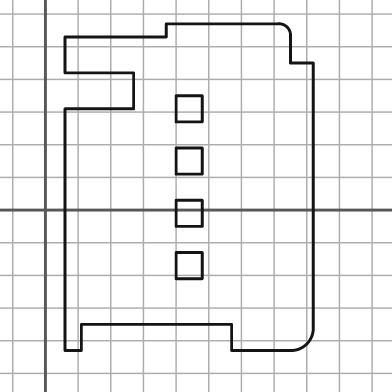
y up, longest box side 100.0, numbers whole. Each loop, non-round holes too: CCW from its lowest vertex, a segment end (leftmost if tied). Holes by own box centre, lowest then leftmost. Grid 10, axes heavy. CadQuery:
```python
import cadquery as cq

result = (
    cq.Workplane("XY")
    .moveTo(6.0, -43.0)
    .lineTo(11.0, -43.0)
    .lineTo(11.0, -35.0)
    .lineTo(57.0, -35.0)
    .lineTo(57.0, -43.0)
    .lineTo(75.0, -43.0)
    .threePointArc((80.0, -41.0), (82.0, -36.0))
    .lineTo(82.0, 45.0)
    .lineTo(75.0, 45.0)
    .lineTo(75.0, 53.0)
    .threePointArc((74.0, 56.0), (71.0, 57.0))
    .lineTo(37.0, 57.0)
    .lineTo(37.0, 53.0)
    .lineTo(6.0, 53.0)
    .lineTo(6.0, 42.0)
    .lineTo(27.0, 42.0)
    .lineTo(27.0, 31.0)
    .lineTo(6.0, 31.0)
    .close()
    .moveTo(40.0, -21.0)
    .lineTo(48.0, -21.0)
    .lineTo(48.0, -13.0)
    .lineTo(40.0, -13.0)
    .close()
    .moveTo(40.0, -5.0)
    .lineTo(48.0, -5.0)
    .lineTo(48.0, 3.0)
    .lineTo(40.0, 3.0)
    .close()
    .moveTo(40.0, 11.0)
    .lineTo(48.0, 11.0)
    .lineTo(48.0, 19.0)
    .lineTo(40.0, 19.0)
    .close()
    .moveTo(40.0, 27.0)
    .lineTo(48.0, 27.0)
    .lineTo(48.0, 35.0)
    .lineTo(40.0, 35.0)
    .close()
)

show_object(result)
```